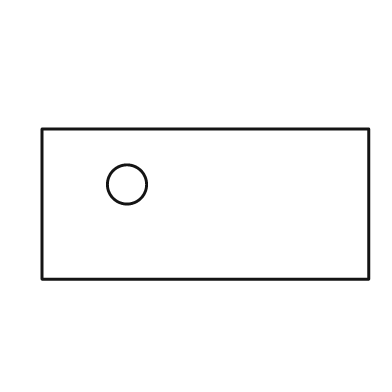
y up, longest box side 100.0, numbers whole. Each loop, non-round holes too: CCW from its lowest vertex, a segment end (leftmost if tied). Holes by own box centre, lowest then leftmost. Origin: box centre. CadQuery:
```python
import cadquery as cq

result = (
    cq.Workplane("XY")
    .moveTo(-50.0, -23.0)
    .lineTo(50.0, -23.0)
    .lineTo(50.0, 23.0)
    .lineTo(-50.0, 23.0)
    .close()
    .moveTo(-24.0, 6.0)
    .circle(6.0)
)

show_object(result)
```